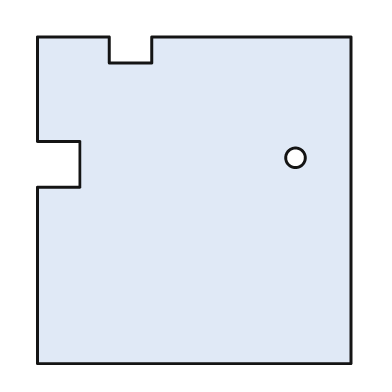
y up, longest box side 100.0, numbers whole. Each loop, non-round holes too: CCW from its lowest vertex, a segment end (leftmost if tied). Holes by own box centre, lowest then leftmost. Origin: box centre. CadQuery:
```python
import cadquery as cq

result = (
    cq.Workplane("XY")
    .moveTo(-48.0, -50.0)
    .lineTo(48.0, -50.0)
    .lineTo(48.0, 50.0)
    .lineTo(-13.0, 50.0)
    .lineTo(-13.0, 42.0)
    .lineTo(-26.0, 42.0)
    .lineTo(-26.0, 50.0)
    .lineTo(-48.0, 50.0)
    .lineTo(-48.0, 18.0)
    .lineTo(-35.0, 18.0)
    .lineTo(-35.0, 4.0)
    .lineTo(-48.0, 4.0)
    .close()
    .moveTo(31.0, 13.0)
    .circle(3.0)
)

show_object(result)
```